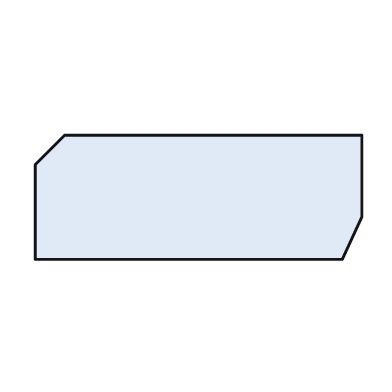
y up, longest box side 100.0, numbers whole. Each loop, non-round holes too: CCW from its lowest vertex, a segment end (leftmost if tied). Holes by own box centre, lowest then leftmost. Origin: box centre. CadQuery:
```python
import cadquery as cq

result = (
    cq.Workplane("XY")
    .moveTo(-50.0, -19.0)
    .lineTo(44.0, -19.0)
    .lineTo(50.0, -6.0)
    .lineTo(50.0, 19.0)
    .lineTo(-41.0, 19.0)
    .lineTo(-50.0, 10.0)
    .close()
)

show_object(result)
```